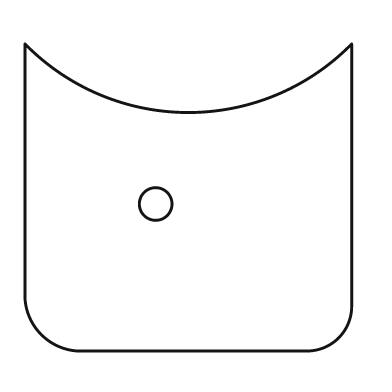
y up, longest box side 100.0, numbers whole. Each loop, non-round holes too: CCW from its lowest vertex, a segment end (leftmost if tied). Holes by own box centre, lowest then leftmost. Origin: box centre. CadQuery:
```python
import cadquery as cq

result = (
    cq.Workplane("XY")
    .moveTo(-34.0, -47.0)
    .lineTo(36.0, -47.0)
    .threePointArc((46.0, -43.0), (50.0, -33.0))
    .lineTo(50.0, 47.0)
    .threePointArc((0.0, 26.0), (-50.0, 47.0))
    .lineTo(-50.0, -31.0)
    .threePointArc((-45.0, -42.0), (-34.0, -47.0))
    .close()
    .moveTo(-10.0, -2.0)
    .circle(5.0)
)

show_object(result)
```